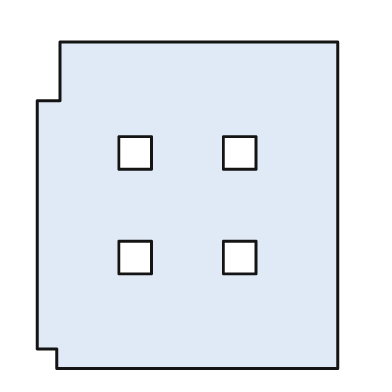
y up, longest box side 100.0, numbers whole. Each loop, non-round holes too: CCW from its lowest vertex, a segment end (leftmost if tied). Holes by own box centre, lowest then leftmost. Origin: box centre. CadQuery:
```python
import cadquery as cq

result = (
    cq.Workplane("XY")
    .moveTo(-40.0, -50.0)
    .lineTo(46.0, -50.0)
    .lineTo(46.0, 50.0)
    .lineTo(-39.0, 50.0)
    .lineTo(-39.0, 32.0)
    .lineTo(-46.0, 32.0)
    .lineTo(-46.0, -44.0)
    .lineTo(-40.0, -44.0)
    .close()
    .moveTo(-21.0, -21.0)
    .lineTo(-11.0, -21.0)
    .lineTo(-11.0, -11.0)
    .lineTo(-21.0, -11.0)
    .close()
    .moveTo(11.0, -21.0)
    .lineTo(21.0, -21.0)
    .lineTo(21.0, -11.0)
    .lineTo(11.0, -11.0)
    .close()
    .moveTo(-21.0, 11.0)
    .lineTo(-11.0, 11.0)
    .lineTo(-11.0, 21.0)
    .lineTo(-21.0, 21.0)
    .close()
    .moveTo(11.0, 11.0)
    .lineTo(21.0, 11.0)
    .lineTo(21.0, 21.0)
    .lineTo(11.0, 21.0)
    .close()
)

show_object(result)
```